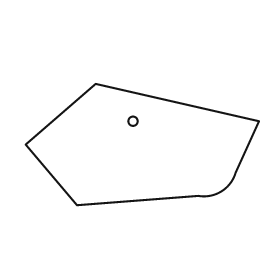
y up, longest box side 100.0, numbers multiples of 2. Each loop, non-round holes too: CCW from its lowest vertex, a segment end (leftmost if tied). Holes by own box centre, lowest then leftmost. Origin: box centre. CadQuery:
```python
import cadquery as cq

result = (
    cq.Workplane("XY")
    .moveTo(-28.0, -26.0)
    .lineTo(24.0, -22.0)
    .threePointArc((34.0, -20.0), (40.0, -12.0))
    .lineTo(50.0, 10.0)
    .lineTo(-20.0, 26.0)
    .lineTo(-50.0, 0.0)
    .close()
    .moveTo(-4.0, 10.0)
    .circle(2.0)
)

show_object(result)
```